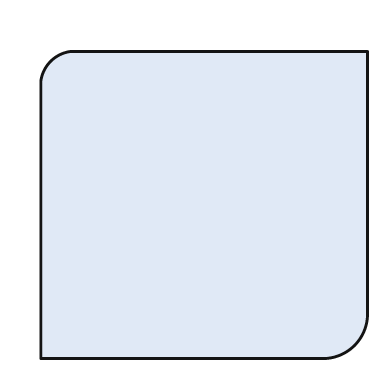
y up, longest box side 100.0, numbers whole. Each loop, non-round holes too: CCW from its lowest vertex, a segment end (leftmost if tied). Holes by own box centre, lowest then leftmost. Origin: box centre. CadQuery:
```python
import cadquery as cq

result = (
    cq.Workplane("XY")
    .moveTo(-50.0, -47.0)
    .lineTo(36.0, -47.0)
    .threePointArc((46.0, -43.0), (50.0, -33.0))
    .lineTo(50.0, 47.0)
    .lineTo(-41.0, 47.0)
    .threePointArc((-47.0, 44.0), (-50.0, 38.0))
    .close()
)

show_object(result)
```